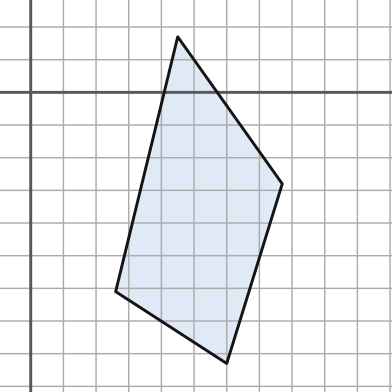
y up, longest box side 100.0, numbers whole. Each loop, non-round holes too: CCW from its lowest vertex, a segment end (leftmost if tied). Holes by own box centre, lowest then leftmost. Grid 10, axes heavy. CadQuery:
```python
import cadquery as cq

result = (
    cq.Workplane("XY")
    .moveTo(60.0, -83.0)
    .lineTo(77.0, -28.0)
    .lineTo(45.0, 17.0)
    .lineTo(26.0, -61.0)
    .close()
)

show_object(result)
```